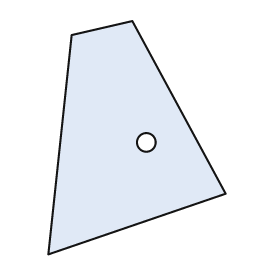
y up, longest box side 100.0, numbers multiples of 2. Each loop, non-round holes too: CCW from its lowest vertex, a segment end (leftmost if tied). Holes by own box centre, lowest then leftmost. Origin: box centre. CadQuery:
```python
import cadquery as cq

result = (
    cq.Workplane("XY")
    .moveTo(-38.0, -50.0)
    .lineTo(38.0, -24.0)
    .lineTo(-2.0, 50.0)
    .lineTo(-28.0, 44.0)
    .close()
    .moveTo(4.0, -2.0)
    .circle(4.0)
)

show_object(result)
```